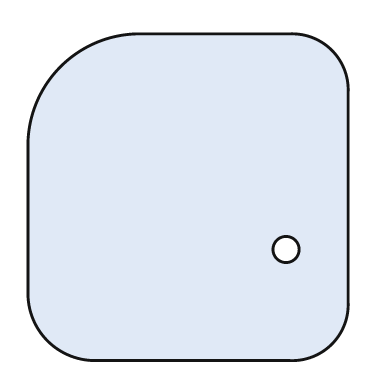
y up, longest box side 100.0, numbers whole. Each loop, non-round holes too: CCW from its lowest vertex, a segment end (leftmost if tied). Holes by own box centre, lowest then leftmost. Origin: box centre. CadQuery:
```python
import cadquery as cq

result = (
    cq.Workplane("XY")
    .moveTo(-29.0, -50.0)
    .lineTo(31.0, -50.0)
    .threePointArc((44.0, -45.0), (49.0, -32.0))
    .lineTo(49.0, 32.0)
    .threePointArc((44.0, 45.0), (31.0, 50.0))
    .lineTo(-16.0, 50.0)
    .threePointArc((-39.0, 40.0), (-49.0, 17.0))
    .lineTo(-49.0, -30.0)
    .threePointArc((-43.0, -44.0), (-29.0, -50.0))
    .close()
    .moveTo(30.0, -16.0)
    .circle(4.0)
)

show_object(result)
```